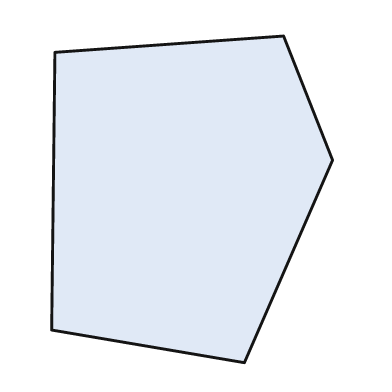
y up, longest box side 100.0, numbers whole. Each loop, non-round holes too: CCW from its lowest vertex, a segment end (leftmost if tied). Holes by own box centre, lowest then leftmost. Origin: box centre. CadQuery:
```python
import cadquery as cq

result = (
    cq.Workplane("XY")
    .moveTo(16.0, -50.0)
    .lineTo(43.0, 12.0)
    .lineTo(28.0, 50.0)
    .lineTo(-42.0, 45.0)
    .lineTo(-43.0, -40.0)
    .close()
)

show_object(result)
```